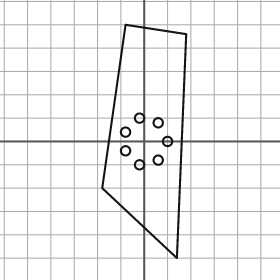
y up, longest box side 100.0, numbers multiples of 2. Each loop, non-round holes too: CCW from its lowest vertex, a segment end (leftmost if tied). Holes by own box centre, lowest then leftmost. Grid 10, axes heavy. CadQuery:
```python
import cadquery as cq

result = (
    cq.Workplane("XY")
    .moveTo(14.0, -50.0)
    .lineTo(18.0, 46.0)
    .lineTo(-8.0, 50.0)
    .lineTo(-18.0, -20.0)
    .close()
    .moveTo(-2.0, -10.0)
    .circle(2.0)
    .moveTo(6.0, -8.0)
    .circle(2.0)
    .moveTo(-8.0, -4.0)
    .circle(2.0)
    .moveTo(10.0, 0.0)
    .circle(2.0)
    .moveTo(-8.0, 4.0)
    .circle(2.0)
    .moveTo(6.0, 8.0)
    .circle(2.0)
    .moveTo(-2.0, 10.0)
    .circle(2.0)
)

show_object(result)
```